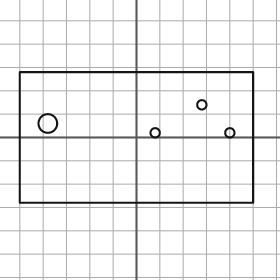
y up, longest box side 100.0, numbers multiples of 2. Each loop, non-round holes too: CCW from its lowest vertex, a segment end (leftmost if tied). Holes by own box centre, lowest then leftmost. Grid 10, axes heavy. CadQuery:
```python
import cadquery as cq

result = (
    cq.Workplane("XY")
    .moveTo(-50.0, -28.0)
    .lineTo(50.0, -28.0)
    .lineTo(50.0, 28.0)
    .lineTo(-50.0, 28.0)
    .close()
    .moveTo(8.0, 2.0)
    .circle(2.0)
    .moveTo(40.0, 2.0)
    .circle(2.0)
    .moveTo(-38.0, 6.0)
    .circle(4.0)
    .moveTo(28.0, 14.0)
    .circle(2.0)
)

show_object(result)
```